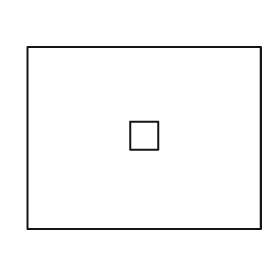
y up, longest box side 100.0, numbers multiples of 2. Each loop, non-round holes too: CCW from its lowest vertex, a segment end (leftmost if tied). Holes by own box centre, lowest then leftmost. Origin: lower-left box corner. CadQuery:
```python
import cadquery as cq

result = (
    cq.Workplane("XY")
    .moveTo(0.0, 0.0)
    .lineTo(100.0, 0.0)
    .lineTo(100.0, 78.0)
    .lineTo(0.0, 78.0)
    .close()
    .moveTo(44.0, 34.0)
    .lineTo(56.0, 34.0)
    .lineTo(56.0, 46.0)
    .lineTo(44.0, 46.0)
    .close()
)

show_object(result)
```